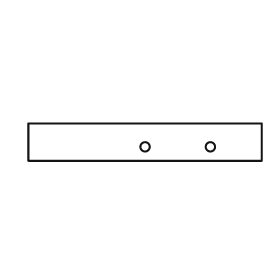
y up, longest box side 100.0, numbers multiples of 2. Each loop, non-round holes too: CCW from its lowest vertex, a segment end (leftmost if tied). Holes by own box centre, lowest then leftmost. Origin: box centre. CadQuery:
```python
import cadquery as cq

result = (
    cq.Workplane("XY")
    .moveTo(-50.0, -8.0)
    .lineTo(50.0, -8.0)
    .lineTo(50.0, 8.0)
    .lineTo(-50.0, 8.0)
    .close()
    .moveTo(0.0, -2.0)
    .circle(2.0)
    .moveTo(28.0, -2.0)
    .circle(2.0)
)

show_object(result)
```